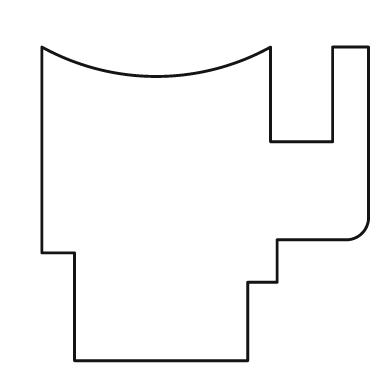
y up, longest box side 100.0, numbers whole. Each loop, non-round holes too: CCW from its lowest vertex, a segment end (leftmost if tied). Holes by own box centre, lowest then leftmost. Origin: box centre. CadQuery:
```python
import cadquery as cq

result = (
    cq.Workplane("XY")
    .moveTo(-40.0, -48.0)
    .lineTo(13.0, -48.0)
    .lineTo(13.0, -24.0)
    .lineTo(22.0, -24.0)
    .lineTo(22.0, -11.0)
    .lineTo(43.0, -11.0)
    .threePointArc((48.0, -9.0), (50.0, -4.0))
    .lineTo(50.0, 48.0)
    .lineTo(39.0, 48.0)
    .lineTo(39.0, 19.0)
    .lineTo(20.0, 19.0)
    .lineTo(20.0, 48.0)
    .threePointArc((-15.0, 39.0), (-50.0, 48.0))
    .lineTo(-50.0, -15.0)
    .lineTo(-40.0, -15.0)
    .close()
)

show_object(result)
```